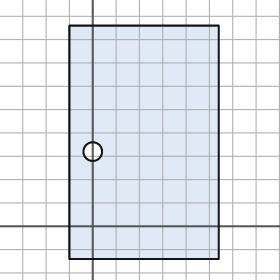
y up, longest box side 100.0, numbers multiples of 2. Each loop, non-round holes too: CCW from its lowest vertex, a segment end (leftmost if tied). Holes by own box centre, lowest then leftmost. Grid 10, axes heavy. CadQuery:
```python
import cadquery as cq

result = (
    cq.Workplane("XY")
    .moveTo(-10.0, -14.0)
    .lineTo(54.0, -14.0)
    .lineTo(54.0, 86.0)
    .lineTo(-10.0, 86.0)
    .close()
    .moveTo(0.0, 32.0)
    .circle(4.0)
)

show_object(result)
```